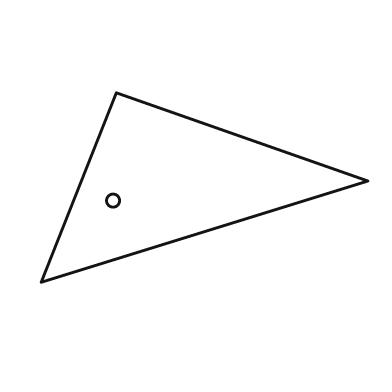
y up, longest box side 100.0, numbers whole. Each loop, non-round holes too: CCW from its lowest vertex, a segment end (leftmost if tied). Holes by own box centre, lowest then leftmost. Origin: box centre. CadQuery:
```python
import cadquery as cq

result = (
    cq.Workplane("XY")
    .moveTo(-50.0, -29.0)
    .lineTo(50.0, 2.0)
    .lineTo(-27.0, 29.0)
    .close()
    .moveTo(-28.0, -4.0)
    .circle(2.0)
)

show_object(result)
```